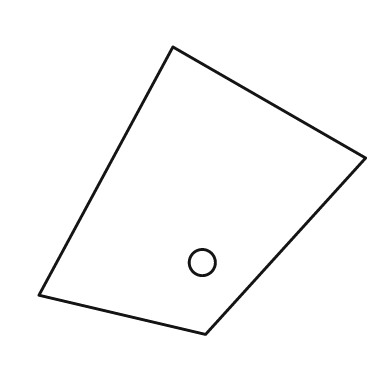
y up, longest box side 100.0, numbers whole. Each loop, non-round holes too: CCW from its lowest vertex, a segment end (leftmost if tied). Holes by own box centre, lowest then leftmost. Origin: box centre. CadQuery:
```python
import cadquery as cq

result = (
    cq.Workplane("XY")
    .moveTo(1.0, -44.0)
    .lineTo(50.0, 10.0)
    .lineTo(-9.0, 44.0)
    .lineTo(-50.0, -32.0)
    .close()
    .moveTo(0.0, -22.0)
    .circle(4.0)
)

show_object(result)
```